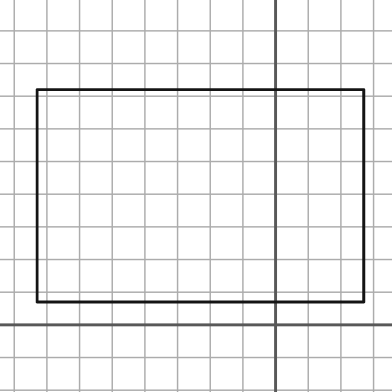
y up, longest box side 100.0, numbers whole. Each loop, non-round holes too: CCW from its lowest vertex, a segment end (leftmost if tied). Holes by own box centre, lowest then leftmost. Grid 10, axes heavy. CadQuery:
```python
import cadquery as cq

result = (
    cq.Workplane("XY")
    .moveTo(-73.0, 7.0)
    .lineTo(27.0, 7.0)
    .lineTo(27.0, 72.0)
    .lineTo(-73.0, 72.0)
    .close()
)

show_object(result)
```